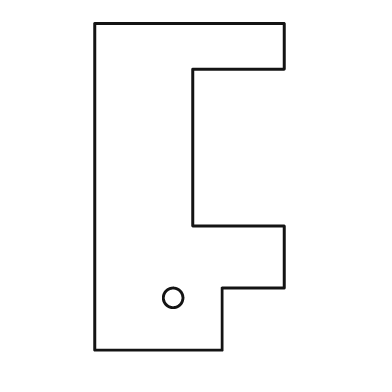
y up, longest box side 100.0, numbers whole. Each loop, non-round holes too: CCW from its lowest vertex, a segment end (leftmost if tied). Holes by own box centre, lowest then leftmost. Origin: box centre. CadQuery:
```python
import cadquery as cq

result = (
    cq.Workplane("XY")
    .moveTo(-29.0, -50.0)
    .lineTo(10.0, -50.0)
    .lineTo(10.0, -31.0)
    .lineTo(29.0, -31.0)
    .lineTo(29.0, -12.0)
    .lineTo(1.0, -12.0)
    .lineTo(1.0, 36.0)
    .lineTo(29.0, 36.0)
    .lineTo(29.0, 50.0)
    .lineTo(-29.0, 50.0)
    .close()
    .moveTo(-5.0, -34.0)
    .circle(3.0)
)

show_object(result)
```